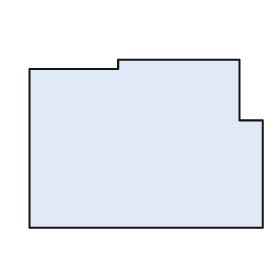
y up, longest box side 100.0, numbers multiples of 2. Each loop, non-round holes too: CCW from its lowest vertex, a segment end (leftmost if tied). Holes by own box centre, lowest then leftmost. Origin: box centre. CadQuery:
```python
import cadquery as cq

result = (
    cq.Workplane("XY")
    .moveTo(-50.0, -36.0)
    .lineTo(50.0, -36.0)
    .lineTo(50.0, 10.0)
    .lineTo(40.0, 10.0)
    .lineTo(40.0, 36.0)
    .lineTo(-12.0, 36.0)
    .lineTo(-12.0, 32.0)
    .lineTo(-50.0, 32.0)
    .close()
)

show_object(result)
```